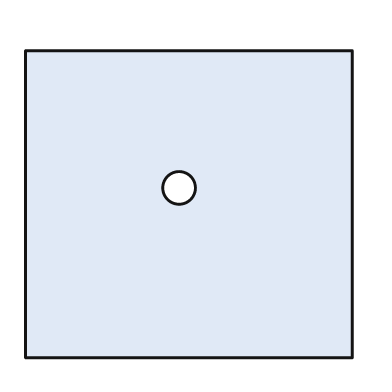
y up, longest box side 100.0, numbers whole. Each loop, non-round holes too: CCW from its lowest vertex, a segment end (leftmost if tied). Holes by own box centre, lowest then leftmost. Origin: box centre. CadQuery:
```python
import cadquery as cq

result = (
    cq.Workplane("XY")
    .moveTo(-50.0, -47.0)
    .lineTo(50.0, -47.0)
    .lineTo(50.0, 47.0)
    .lineTo(-50.0, 47.0)
    .close()
    .moveTo(-3.0, 5.0)
    .circle(5.0)
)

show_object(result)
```